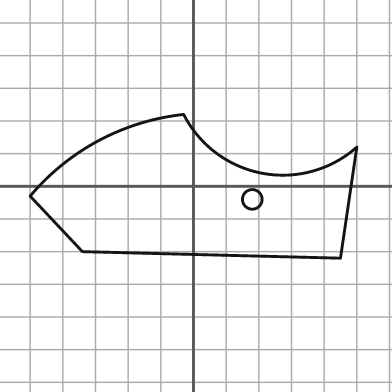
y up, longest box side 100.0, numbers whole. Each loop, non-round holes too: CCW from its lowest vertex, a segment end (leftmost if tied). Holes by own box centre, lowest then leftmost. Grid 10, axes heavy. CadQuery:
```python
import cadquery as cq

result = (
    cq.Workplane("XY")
    .moveTo(45.0, -22.0)
    .lineTo(50.0, 12.0)
    .threePointArc((21.0, 4.0), (-3.0, 22.0))
    .threePointArc((-29.0, 14.0), (-50.0, -3.0))
    .lineTo(-34.0, -20.0)
    .close()
    .moveTo(18.0, -4.0)
    .circle(3.0)
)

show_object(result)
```